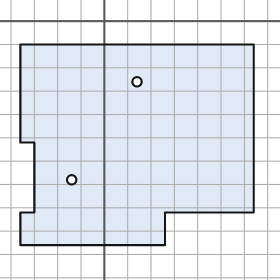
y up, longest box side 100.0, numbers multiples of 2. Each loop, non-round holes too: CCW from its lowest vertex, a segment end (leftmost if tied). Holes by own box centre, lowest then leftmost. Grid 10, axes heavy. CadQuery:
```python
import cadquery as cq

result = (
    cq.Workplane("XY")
    .moveTo(-36.0, -96.0)
    .lineTo(26.0, -96.0)
    .lineTo(26.0, -82.0)
    .lineTo(64.0, -82.0)
    .lineTo(64.0, -10.0)
    .lineTo(-36.0, -10.0)
    .lineTo(-36.0, -52.0)
    .lineTo(-30.0, -52.0)
    .lineTo(-30.0, -82.0)
    .lineTo(-36.0, -82.0)
    .close()
    .moveTo(-14.0, -68.0)
    .circle(2.0)
    .moveTo(14.0, -26.0)
    .circle(2.0)
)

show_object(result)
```